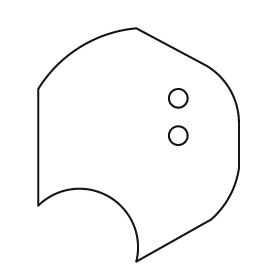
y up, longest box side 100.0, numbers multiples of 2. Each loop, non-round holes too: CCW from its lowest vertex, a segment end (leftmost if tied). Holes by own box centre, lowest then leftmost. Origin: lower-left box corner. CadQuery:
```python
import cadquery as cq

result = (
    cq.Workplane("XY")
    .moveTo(42.0, 0.0)
    .lineTo(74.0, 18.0)
    .threePointArc((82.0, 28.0), (86.0, 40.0))
    .lineTo(86.0, 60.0)
    .threePointArc((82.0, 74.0), (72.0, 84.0))
    .lineTo(42.0, 100.0)
    .threePointArc((18.0, 92.0), (0.0, 74.0))
    .lineTo(0.0, 24.0)
    .threePointArc((30.0, 28.0), (42.0, 0.0))
    .close()
    .moveTo(60.0, 54.0)
    .circle(4.0)
    .moveTo(60.0, 70.0)
    .circle(4.0)
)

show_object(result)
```